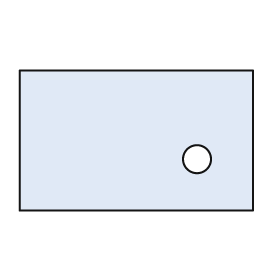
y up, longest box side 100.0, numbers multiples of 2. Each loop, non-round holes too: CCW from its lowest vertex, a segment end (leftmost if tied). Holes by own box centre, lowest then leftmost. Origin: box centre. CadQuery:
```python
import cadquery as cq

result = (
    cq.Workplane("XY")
    .moveTo(-50.0, -30.0)
    .lineTo(50.0, -30.0)
    .lineTo(50.0, 30.0)
    .lineTo(-50.0, 30.0)
    .close()
    .moveTo(26.0, -8.0)
    .circle(6.0)
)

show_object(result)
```